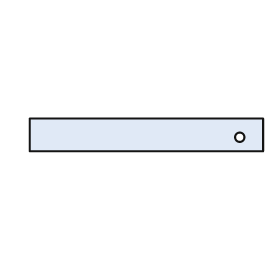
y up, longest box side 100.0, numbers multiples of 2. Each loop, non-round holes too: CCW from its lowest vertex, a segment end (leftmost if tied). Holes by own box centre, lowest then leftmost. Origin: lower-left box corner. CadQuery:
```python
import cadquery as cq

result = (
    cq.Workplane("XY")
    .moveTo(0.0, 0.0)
    .lineTo(100.0, 0.0)
    .lineTo(100.0, 14.0)
    .lineTo(0.0, 14.0)
    .close()
    .moveTo(90.0, 6.0)
    .circle(2.0)
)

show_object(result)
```